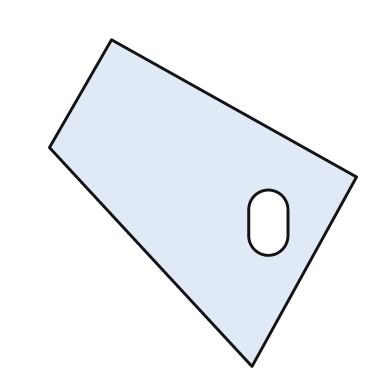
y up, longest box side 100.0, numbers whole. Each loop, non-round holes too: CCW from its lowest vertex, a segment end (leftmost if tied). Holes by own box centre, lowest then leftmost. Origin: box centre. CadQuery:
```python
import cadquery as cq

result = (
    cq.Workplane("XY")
    .moveTo(15.0, -50.0)
    .lineTo(47.0, 8.0)
    .lineTo(-28.0, 50.0)
    .lineTo(-47.0, 17.0)
    .close()
    .moveTo(14.0, -10.0)
    .threePointArc((20.0, -16.0), (26.0, -10.0))
    .lineTo(26.0, -2.0)
    .threePointArc((20.0, 4.0), (14.0, -2.0))
    .close()
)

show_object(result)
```